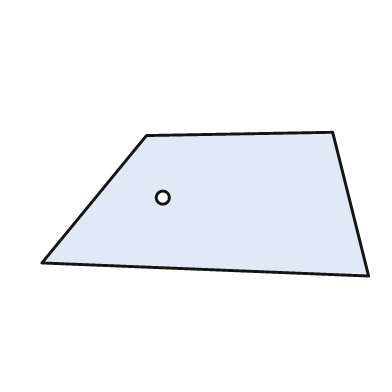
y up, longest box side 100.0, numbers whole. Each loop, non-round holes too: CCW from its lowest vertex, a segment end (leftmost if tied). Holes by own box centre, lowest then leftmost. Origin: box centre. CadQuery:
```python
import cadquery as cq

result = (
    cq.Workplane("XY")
    .moveTo(50.0, -22.0)
    .lineTo(39.0, 22.0)
    .lineTo(-18.0, 21.0)
    .lineTo(-50.0, -18.0)
    .close()
    .moveTo(-13.0, 2.0)
    .circle(2.0)
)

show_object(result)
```